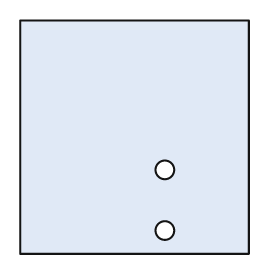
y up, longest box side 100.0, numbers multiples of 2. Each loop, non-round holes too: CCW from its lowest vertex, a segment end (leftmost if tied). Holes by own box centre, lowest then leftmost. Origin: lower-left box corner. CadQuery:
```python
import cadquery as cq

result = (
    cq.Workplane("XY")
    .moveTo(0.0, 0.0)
    .lineTo(98.0, 0.0)
    .lineTo(98.0, 100.0)
    .lineTo(0.0, 100.0)
    .close()
    .moveTo(62.0, 10.0)
    .circle(4.0)
    .moveTo(62.0, 36.0)
    .circle(4.0)
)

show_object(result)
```